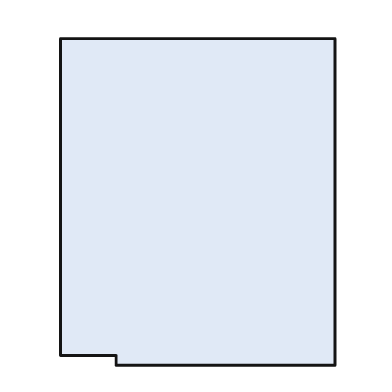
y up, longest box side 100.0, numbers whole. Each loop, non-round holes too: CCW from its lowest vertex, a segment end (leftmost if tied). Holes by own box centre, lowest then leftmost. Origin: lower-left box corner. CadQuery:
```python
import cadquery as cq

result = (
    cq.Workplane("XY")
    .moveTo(17.0, 0.0)
    .lineTo(84.0, 0.0)
    .lineTo(84.0, 100.0)
    .lineTo(0.0, 100.0)
    .lineTo(0.0, 3.0)
    .lineTo(17.0, 3.0)
    .close()
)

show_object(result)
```